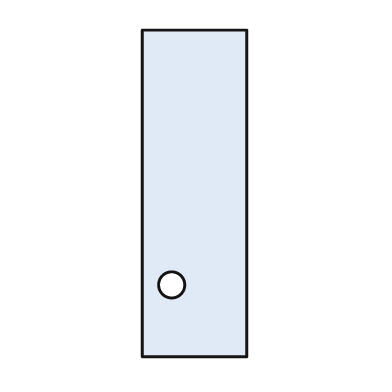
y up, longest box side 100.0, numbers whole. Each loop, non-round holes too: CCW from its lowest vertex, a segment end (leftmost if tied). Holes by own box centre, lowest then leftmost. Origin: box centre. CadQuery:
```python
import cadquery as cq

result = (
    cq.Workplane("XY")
    .moveTo(-16.0, -50.0)
    .lineTo(16.0, -50.0)
    .lineTo(16.0, 50.0)
    .lineTo(-16.0, 50.0)
    .close()
    .moveTo(-7.0, -28.0)
    .circle(4.0)
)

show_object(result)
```